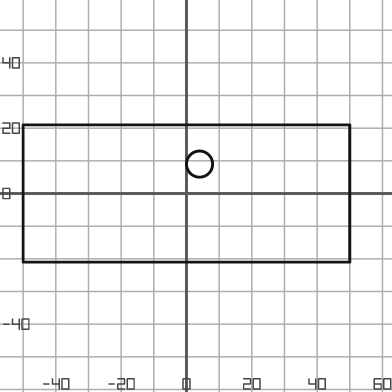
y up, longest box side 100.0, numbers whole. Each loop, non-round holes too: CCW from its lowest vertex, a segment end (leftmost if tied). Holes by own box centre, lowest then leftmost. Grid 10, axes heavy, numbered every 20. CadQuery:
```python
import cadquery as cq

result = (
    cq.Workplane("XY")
    .moveTo(-50.0, -21.0)
    .lineTo(50.0, -21.0)
    .lineTo(50.0, 21.0)
    .lineTo(-50.0, 21.0)
    .close()
    .moveTo(4.0, 9.0)
    .circle(4.0)
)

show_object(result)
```